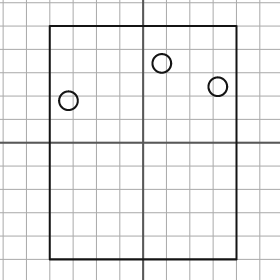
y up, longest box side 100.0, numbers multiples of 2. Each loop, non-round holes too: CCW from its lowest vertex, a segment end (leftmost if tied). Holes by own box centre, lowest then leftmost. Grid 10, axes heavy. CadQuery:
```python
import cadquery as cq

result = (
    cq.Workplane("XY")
    .moveTo(-40.0, -50.0)
    .lineTo(40.0, -50.0)
    .lineTo(40.0, 50.0)
    .lineTo(-40.0, 50.0)
    .close()
    .moveTo(-32.0, 18.0)
    .circle(4.0)
    .moveTo(32.0, 24.0)
    .circle(4.0)
    .moveTo(8.0, 34.0)
    .circle(4.0)
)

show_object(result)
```